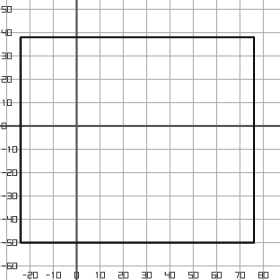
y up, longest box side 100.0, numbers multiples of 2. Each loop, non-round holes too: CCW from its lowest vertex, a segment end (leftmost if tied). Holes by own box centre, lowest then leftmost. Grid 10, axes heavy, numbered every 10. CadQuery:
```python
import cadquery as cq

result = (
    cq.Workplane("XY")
    .moveTo(-24.0, -50.0)
    .lineTo(76.0, -50.0)
    .lineTo(76.0, 38.0)
    .lineTo(-24.0, 38.0)
    .close()
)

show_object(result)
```